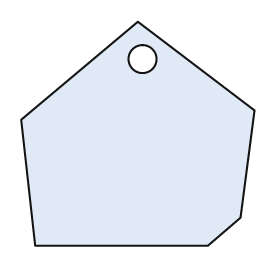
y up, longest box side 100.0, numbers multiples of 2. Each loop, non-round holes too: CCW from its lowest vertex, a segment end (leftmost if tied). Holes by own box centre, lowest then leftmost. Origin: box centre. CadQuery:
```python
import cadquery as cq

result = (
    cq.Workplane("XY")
    .moveTo(-44.0, -48.0)
    .lineTo(30.0, -48.0)
    .lineTo(44.0, -36.0)
    .lineTo(50.0, 10.0)
    .lineTo(0.0, 48.0)
    .lineTo(-50.0, 6.0)
    .close()
    .moveTo(2.0, 32.0)
    .circle(6.0)
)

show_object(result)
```